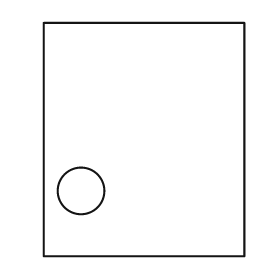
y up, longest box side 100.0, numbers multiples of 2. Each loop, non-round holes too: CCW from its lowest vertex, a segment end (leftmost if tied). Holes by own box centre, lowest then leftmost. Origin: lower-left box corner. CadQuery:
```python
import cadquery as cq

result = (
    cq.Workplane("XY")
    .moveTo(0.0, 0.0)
    .lineTo(86.0, 0.0)
    .lineTo(86.0, 100.0)
    .lineTo(0.0, 100.0)
    .close()
    .moveTo(16.0, 28.0)
    .circle(10.0)
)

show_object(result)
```